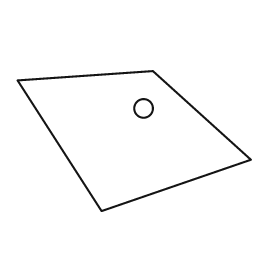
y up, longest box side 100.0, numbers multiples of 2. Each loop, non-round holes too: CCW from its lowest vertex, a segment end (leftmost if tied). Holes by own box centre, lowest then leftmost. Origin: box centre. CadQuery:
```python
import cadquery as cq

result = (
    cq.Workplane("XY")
    .moveTo(-14.0, -30.0)
    .lineTo(50.0, -8.0)
    .lineTo(8.0, 30.0)
    .lineTo(-50.0, 26.0)
    .close()
    .moveTo(4.0, 14.0)
    .circle(4.0)
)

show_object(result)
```